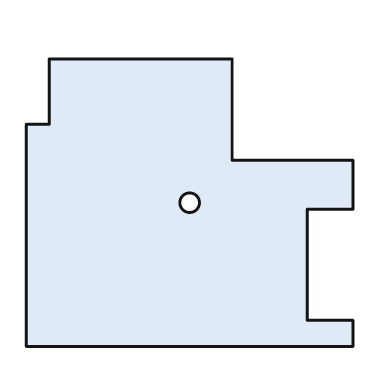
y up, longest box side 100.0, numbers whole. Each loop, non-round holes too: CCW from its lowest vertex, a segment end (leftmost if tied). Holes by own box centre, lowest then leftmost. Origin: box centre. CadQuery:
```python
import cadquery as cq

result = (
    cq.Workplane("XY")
    .moveTo(-50.0, -44.0)
    .lineTo(50.0, -44.0)
    .lineTo(50.0, -36.0)
    .lineTo(36.0, -36.0)
    .lineTo(36.0, -2.0)
    .lineTo(50.0, -2.0)
    .lineTo(50.0, 13.0)
    .lineTo(13.0, 13.0)
    .lineTo(13.0, 44.0)
    .lineTo(-43.0, 44.0)
    .lineTo(-43.0, 24.0)
    .lineTo(-50.0, 24.0)
    .close()
    .moveTo(0.0, 0.0)
    .circle(3.0)
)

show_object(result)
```